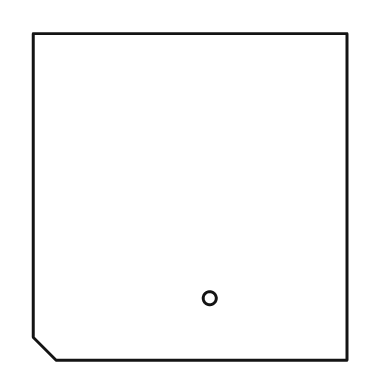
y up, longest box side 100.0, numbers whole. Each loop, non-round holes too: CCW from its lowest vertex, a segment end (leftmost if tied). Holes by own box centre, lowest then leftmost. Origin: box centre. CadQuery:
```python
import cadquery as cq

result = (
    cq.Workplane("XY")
    .moveTo(-41.0, -50.0)
    .lineTo(48.0, -50.0)
    .lineTo(48.0, 50.0)
    .lineTo(-48.0, 50.0)
    .lineTo(-48.0, -43.0)
    .close()
    .moveTo(6.0, -31.0)
    .circle(2.0)
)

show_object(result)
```